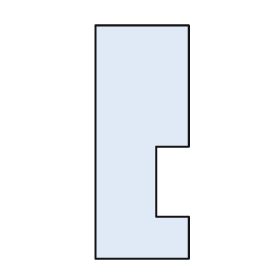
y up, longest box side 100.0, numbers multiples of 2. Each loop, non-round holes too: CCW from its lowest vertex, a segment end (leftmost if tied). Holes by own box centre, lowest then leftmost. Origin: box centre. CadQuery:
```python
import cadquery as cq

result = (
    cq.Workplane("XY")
    .moveTo(-20.0, -50.0)
    .lineTo(20.0, -50.0)
    .lineTo(20.0, -32.0)
    .lineTo(6.0, -32.0)
    .lineTo(6.0, -2.0)
    .lineTo(20.0, -2.0)
    .lineTo(20.0, 50.0)
    .lineTo(-20.0, 50.0)
    .close()
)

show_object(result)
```